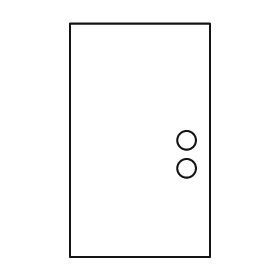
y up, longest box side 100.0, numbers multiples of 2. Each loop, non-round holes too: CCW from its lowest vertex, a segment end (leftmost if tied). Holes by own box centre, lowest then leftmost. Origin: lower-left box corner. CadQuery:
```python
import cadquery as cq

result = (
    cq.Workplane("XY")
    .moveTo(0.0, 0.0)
    .lineTo(60.0, 0.0)
    .lineTo(60.0, 100.0)
    .lineTo(0.0, 100.0)
    .close()
    .moveTo(50.0, 38.0)
    .circle(4.0)
    .moveTo(50.0, 50.0)
    .circle(4.0)
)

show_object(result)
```